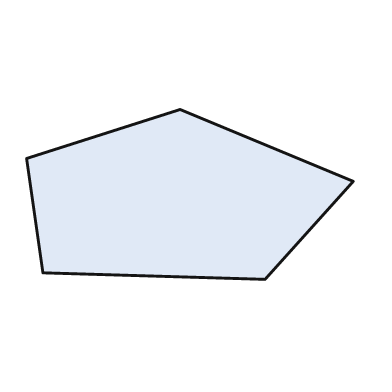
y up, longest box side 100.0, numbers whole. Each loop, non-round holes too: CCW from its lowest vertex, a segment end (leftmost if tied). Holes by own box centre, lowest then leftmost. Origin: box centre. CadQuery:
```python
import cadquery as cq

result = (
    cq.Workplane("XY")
    .moveTo(23.0, -26.0)
    .lineTo(50.0, 4.0)
    .lineTo(-3.0, 26.0)
    .lineTo(-50.0, 11.0)
    .lineTo(-45.0, -24.0)
    .close()
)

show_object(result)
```